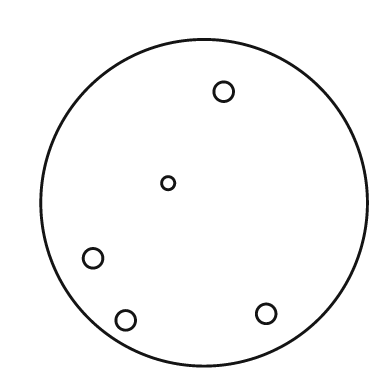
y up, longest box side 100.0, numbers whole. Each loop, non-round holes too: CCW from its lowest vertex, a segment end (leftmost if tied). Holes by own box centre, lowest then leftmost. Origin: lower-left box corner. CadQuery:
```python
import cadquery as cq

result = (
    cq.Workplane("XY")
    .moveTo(50.0, 50.0)
    .circle(50.0)
    .moveTo(26.0, 14.0)
    .circle(3.0)
    .moveTo(69.0, 16.0)
    .circle(3.0)
    .moveTo(16.0, 33.0)
    .circle(3.0)
    .moveTo(39.0, 56.0)
    .circle(2.0)
    .moveTo(56.0, 84.0)
    .circle(3.0)
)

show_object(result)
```